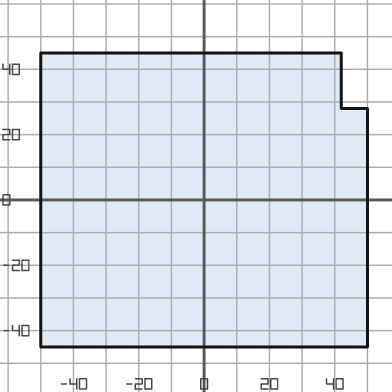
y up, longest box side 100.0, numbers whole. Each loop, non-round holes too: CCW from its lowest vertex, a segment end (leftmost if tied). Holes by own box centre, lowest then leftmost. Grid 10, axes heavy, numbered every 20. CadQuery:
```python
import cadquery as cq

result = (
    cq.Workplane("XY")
    .moveTo(-50.0, -45.0)
    .lineTo(50.0, -45.0)
    .lineTo(50.0, 28.0)
    .lineTo(42.0, 28.0)
    .lineTo(42.0, 45.0)
    .lineTo(-50.0, 45.0)
    .close()
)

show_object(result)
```